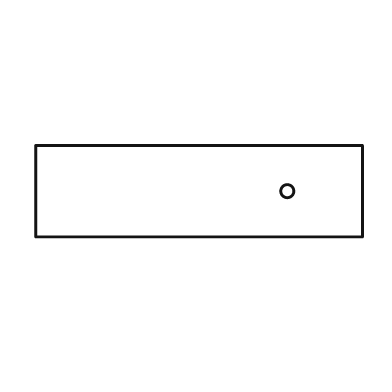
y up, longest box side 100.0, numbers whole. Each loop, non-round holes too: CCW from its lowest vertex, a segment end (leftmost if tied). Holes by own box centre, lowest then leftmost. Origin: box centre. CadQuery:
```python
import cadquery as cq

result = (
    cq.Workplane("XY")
    .moveTo(-50.0, -14.0)
    .lineTo(50.0, -14.0)
    .lineTo(50.0, 14.0)
    .lineTo(-50.0, 14.0)
    .close()
    .moveTo(27.0, 0.0)
    .circle(2.0)
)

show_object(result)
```